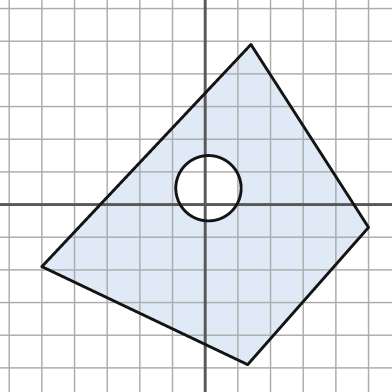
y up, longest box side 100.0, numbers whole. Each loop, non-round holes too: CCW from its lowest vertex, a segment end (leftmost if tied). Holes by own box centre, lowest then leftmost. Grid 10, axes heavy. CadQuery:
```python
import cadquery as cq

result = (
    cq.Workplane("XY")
    .moveTo(13.0, -49.0)
    .lineTo(50.0, -7.0)
    .lineTo(14.0, 49.0)
    .lineTo(-50.0, -19.0)
    .close()
    .moveTo(1.0, 5.0)
    .circle(10.0)
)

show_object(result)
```